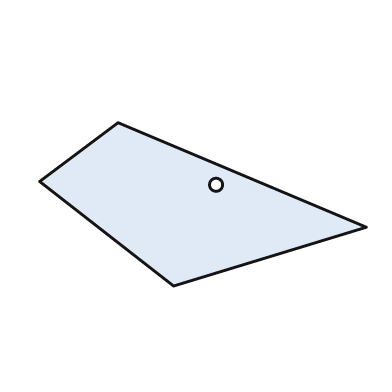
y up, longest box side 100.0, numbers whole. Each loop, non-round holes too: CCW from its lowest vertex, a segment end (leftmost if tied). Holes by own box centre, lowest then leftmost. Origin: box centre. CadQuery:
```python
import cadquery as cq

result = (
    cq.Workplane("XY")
    .moveTo(-9.0, -25.0)
    .lineTo(50.0, -7.0)
    .lineTo(-26.0, 25.0)
    .lineTo(-50.0, 7.0)
    .close()
    .moveTo(4.0, 6.0)
    .circle(2.0)
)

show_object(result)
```